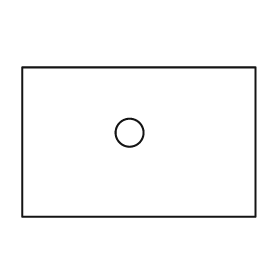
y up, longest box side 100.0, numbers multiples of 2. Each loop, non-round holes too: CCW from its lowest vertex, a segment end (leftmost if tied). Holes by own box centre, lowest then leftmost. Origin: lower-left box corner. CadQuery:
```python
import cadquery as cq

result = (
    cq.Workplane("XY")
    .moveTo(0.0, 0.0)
    .lineTo(100.0, 0.0)
    .lineTo(100.0, 64.0)
    .lineTo(0.0, 64.0)
    .close()
    .moveTo(46.0, 36.0)
    .circle(6.0)
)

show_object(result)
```